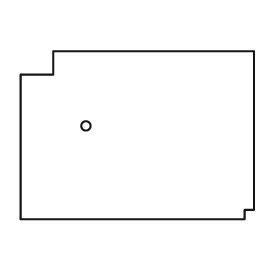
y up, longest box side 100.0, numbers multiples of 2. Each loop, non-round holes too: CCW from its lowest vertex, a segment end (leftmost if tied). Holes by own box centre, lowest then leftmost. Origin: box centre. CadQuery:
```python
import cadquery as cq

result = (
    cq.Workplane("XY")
    .moveTo(-50.0, -36.0)
    .lineTo(46.0, -36.0)
    .lineTo(46.0, -32.0)
    .lineTo(50.0, -32.0)
    .lineTo(50.0, 36.0)
    .lineTo(-36.0, 36.0)
    .lineTo(-36.0, 26.0)
    .lineTo(-50.0, 26.0)
    .close()
    .moveTo(-22.0, 4.0)
    .circle(2.0)
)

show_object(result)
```